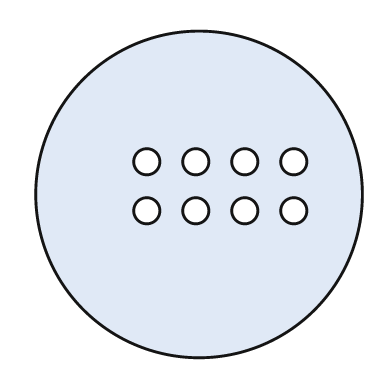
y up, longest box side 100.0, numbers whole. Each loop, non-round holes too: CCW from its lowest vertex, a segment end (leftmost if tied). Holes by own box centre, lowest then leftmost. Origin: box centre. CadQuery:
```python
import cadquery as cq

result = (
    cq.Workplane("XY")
    .moveTo(0.0, 0.0)
    .circle(50.0)
    .moveTo(-16.0, -5.0)
    .circle(4.0)
    .moveTo(-1.0, -5.0)
    .circle(4.0)
    .moveTo(14.0, -5.0)
    .circle(4.0)
    .moveTo(29.0, -5.0)
    .circle(4.0)
    .moveTo(-16.0, 10.0)
    .circle(4.0)
    .moveTo(-1.0, 10.0)
    .circle(4.0)
    .moveTo(14.0, 10.0)
    .circle(4.0)
    .moveTo(29.0, 10.0)
    .circle(4.0)
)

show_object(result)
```